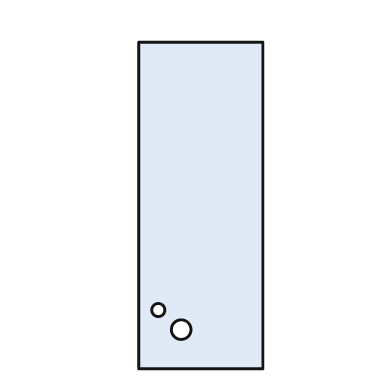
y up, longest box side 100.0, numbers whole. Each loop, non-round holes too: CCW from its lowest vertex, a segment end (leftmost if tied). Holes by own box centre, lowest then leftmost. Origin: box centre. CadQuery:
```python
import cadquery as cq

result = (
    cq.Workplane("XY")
    .moveTo(-19.0, -50.0)
    .lineTo(19.0, -50.0)
    .lineTo(19.0, 50.0)
    .lineTo(-19.0, 50.0)
    .close()
    .moveTo(-6.0, -38.0)
    .circle(3.0)
    .moveTo(-13.0, -32.0)
    .circle(2.0)
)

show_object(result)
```